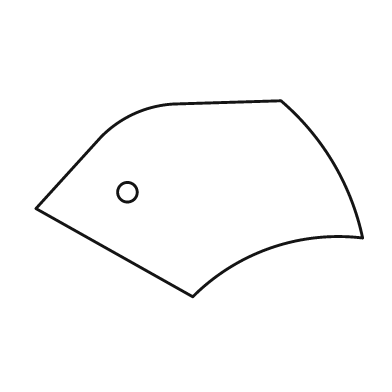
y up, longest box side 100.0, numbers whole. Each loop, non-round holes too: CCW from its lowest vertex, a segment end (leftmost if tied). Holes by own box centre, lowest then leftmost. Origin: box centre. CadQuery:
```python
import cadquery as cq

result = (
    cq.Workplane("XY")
    .moveTo(-2.0, -30.0)
    .threePointArc((22.0, -15.0), (50.0, -12.0))
    .threePointArc((41.0, 11.0), (25.0, 30.0))
    .lineTo(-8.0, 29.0)
    .threePointArc((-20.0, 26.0), (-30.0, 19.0))
    .lineTo(-50.0, -3.0)
    .close()
    .moveTo(-22.0, 2.0)
    .circle(3.0)
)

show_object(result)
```